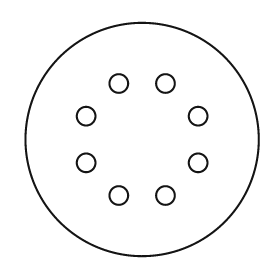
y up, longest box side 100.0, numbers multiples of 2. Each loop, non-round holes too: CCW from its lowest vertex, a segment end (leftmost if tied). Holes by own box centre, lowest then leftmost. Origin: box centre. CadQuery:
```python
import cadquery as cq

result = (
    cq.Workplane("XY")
    .moveTo(0.0, 0.0)
    .circle(50.0)
    .moveTo(-10.0, -24.0)
    .circle(4.0)
    .moveTo(10.0, -24.0)
    .circle(4.0)
    .moveTo(-24.0, -10.0)
    .circle(4.0)
    .moveTo(24.0, -10.0)
    .circle(4.0)
    .moveTo(-24.0, 10.0)
    .circle(4.0)
    .moveTo(24.0, 10.0)
    .circle(4.0)
    .moveTo(-10.0, 24.0)
    .circle(4.0)
    .moveTo(10.0, 24.0)
    .circle(4.0)
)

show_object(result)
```